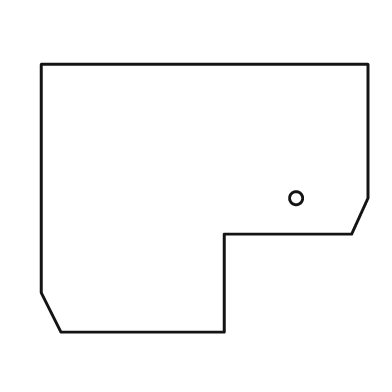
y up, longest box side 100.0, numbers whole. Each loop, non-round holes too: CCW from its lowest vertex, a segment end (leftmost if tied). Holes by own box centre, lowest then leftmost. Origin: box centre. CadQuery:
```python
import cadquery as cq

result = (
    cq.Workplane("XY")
    .moveTo(-44.0, -41.0)
    .lineTo(6.0, -41.0)
    .lineTo(6.0, -11.0)
    .lineTo(45.0, -11.0)
    .lineTo(50.0, 0.0)
    .lineTo(50.0, 41.0)
    .lineTo(-50.0, 41.0)
    .lineTo(-50.0, -29.0)
    .close()
    .moveTo(28.0, 0.0)
    .circle(2.0)
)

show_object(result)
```